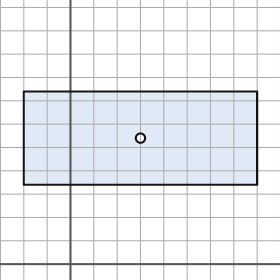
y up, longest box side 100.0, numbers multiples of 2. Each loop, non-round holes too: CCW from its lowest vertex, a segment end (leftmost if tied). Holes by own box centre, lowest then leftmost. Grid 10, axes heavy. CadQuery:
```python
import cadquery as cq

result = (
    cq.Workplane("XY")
    .moveTo(-20.0, 34.0)
    .lineTo(80.0, 34.0)
    .lineTo(80.0, 74.0)
    .lineTo(-20.0, 74.0)
    .close()
    .moveTo(30.0, 54.0)
    .circle(2.0)
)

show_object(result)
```